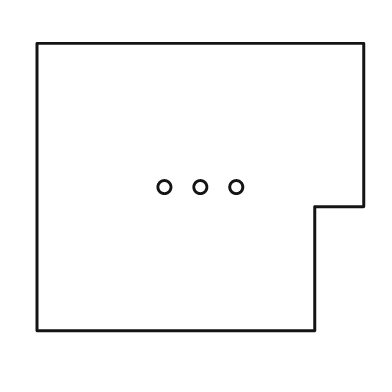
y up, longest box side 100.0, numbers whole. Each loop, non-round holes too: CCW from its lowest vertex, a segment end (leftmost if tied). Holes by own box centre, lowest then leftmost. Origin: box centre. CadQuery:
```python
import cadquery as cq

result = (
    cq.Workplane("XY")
    .moveTo(-50.0, -44.0)
    .lineTo(35.0, -44.0)
    .lineTo(35.0, -6.0)
    .lineTo(50.0, -6.0)
    .lineTo(50.0, 44.0)
    .lineTo(-50.0, 44.0)
    .close()
    .moveTo(-11.0, 0.0)
    .circle(2.0)
    .moveTo(0.0, 0.0)
    .circle(2.0)
    .moveTo(11.0, 0.0)
    .circle(2.0)
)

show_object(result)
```